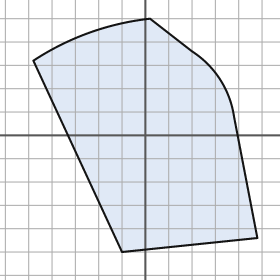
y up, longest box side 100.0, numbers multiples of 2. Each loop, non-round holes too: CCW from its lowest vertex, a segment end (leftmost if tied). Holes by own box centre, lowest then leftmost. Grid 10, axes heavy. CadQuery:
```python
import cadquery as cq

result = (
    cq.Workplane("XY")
    .moveTo(-10.0, -50.0)
    .lineTo(48.0, -44.0)
    .lineTo(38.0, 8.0)
    .threePointArc((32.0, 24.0), (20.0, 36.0))
    .lineTo(2.0, 50.0)
    .threePointArc((-24.0, 44.0), (-48.0, 32.0))
    .close()
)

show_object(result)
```